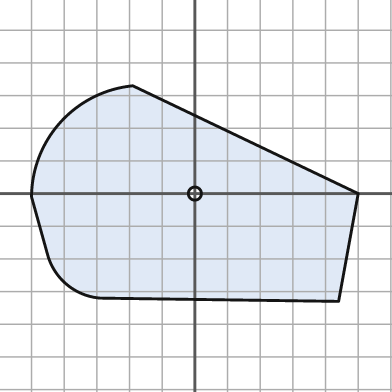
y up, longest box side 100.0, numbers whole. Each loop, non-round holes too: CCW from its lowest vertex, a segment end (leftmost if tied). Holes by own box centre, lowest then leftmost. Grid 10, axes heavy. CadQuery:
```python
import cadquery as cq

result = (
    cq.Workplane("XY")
    .moveTo(44.0, -33.0)
    .lineTo(50.0, 0.0)
    .lineTo(-19.0, 33.0)
    .threePointArc((-41.0, 22.0), (-50.0, -1.0))
    .lineTo(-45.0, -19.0)
    .threePointArc((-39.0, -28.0), (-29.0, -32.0))
    .close()
    .moveTo(0.0, 0.0)
    .circle(2.0)
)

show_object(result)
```